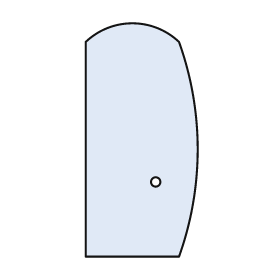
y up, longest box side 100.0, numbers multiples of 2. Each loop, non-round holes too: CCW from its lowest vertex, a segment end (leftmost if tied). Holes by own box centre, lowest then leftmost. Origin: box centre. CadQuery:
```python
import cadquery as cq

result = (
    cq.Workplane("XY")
    .moveTo(-24.0, -50.0)
    .lineTo(16.0, -50.0)
    .threePointArc((24.0, -4.0), (16.0, 42.0))
    .threePointArc((-4.0, 50.0), (-24.0, 42.0))
    .close()
    .moveTo(6.0, -18.0)
    .circle(2.0)
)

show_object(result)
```